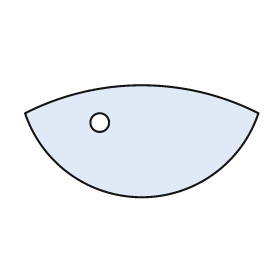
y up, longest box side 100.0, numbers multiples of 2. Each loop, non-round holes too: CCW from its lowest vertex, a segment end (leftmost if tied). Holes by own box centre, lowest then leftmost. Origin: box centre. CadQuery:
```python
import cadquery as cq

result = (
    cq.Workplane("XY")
    .moveTo(-50.0, 12.0)
    .threePointArc((0.0, -24.0), (50.0, 12.0))
    .threePointArc((0.0, 24.0), (-50.0, 12.0))
    .close()
    .moveTo(-18.0, 8.0)
    .circle(4.0)
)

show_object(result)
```